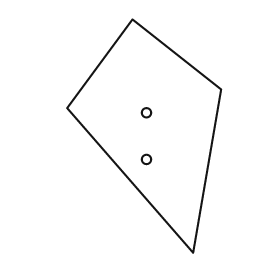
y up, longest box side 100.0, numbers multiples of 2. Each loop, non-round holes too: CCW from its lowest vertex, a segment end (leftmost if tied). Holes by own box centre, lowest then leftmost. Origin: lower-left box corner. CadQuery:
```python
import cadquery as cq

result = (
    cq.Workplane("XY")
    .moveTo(54.0, 0.0)
    .lineTo(66.0, 70.0)
    .lineTo(28.0, 100.0)
    .lineTo(0.0, 62.0)
    .close()
    .moveTo(34.0, 40.0)
    .circle(2.0)
    .moveTo(34.0, 60.0)
    .circle(2.0)
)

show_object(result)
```